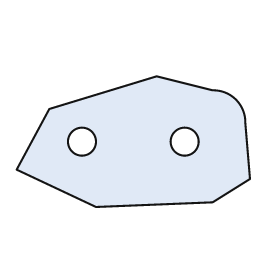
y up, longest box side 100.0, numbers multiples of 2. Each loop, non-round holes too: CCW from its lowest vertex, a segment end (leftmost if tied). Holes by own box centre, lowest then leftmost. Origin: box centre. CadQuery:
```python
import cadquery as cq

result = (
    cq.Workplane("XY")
    .moveTo(-16.0, -28.0)
    .lineTo(34.0, -26.0)
    .lineTo(50.0, -16.0)
    .lineTo(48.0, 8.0)
    .threePointArc((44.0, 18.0), (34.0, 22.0))
    .lineTo(10.0, 28.0)
    .lineTo(-36.0, 14.0)
    .lineTo(-50.0, -12.0)
    .close()
    .moveTo(-22.0, 0.0)
    .circle(6.0)
    .moveTo(22.0, 0.0)
    .circle(6.0)
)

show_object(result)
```